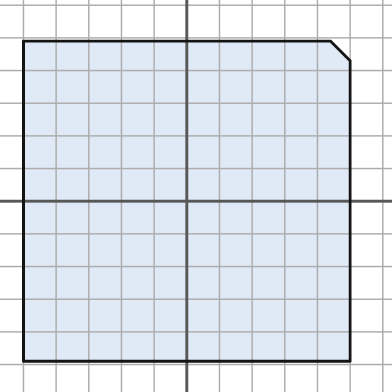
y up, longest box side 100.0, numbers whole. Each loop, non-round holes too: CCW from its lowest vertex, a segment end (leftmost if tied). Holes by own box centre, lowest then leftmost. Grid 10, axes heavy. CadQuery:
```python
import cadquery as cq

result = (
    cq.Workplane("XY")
    .moveTo(-50.0, -49.0)
    .lineTo(50.0, -49.0)
    .lineTo(50.0, 43.0)
    .lineTo(44.0, 49.0)
    .lineTo(-50.0, 49.0)
    .close()
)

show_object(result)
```